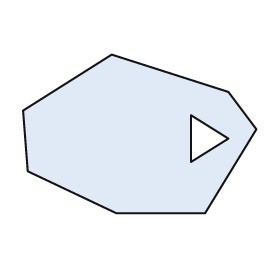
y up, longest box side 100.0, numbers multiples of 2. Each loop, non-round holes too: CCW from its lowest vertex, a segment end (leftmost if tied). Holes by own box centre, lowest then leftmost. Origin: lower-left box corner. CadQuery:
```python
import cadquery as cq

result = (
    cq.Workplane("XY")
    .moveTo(40.0, 0.0)
    .lineTo(78.0, 0.0)
    .lineTo(100.0, 36.0)
    .lineTo(88.0, 52.0)
    .lineTo(38.0, 68.0)
    .lineTo(0.0, 44.0)
    .lineTo(2.0, 18.0)
    .close()
    .moveTo(72.0, 22.0)
    .lineTo(88.0, 32.0)
    .lineTo(72.0, 42.0)
    .close()
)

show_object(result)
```